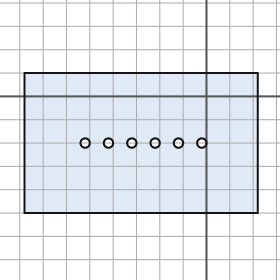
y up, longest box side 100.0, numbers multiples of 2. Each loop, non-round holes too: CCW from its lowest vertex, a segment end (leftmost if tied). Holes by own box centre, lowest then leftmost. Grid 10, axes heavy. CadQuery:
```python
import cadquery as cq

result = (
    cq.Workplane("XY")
    .moveTo(-78.0, -50.0)
    .lineTo(22.0, -50.0)
    .lineTo(22.0, 10.0)
    .lineTo(-78.0, 10.0)
    .close()
    .moveTo(-52.0, -20.0)
    .circle(2.0)
    .moveTo(-42.0, -20.0)
    .circle(2.0)
    .moveTo(-32.0, -20.0)
    .circle(2.0)
    .moveTo(-22.0, -20.0)
    .circle(2.0)
    .moveTo(-12.0, -20.0)
    .circle(2.0)
    .moveTo(-2.0, -20.0)
    .circle(2.0)
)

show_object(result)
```